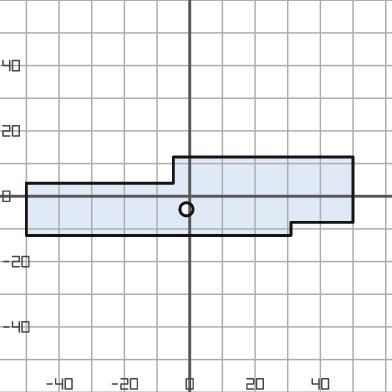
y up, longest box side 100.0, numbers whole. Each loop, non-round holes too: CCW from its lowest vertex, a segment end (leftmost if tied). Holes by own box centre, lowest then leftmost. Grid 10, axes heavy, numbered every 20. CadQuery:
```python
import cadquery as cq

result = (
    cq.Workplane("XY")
    .moveTo(-50.0, -12.0)
    .lineTo(31.0, -12.0)
    .lineTo(31.0, -8.0)
    .lineTo(50.0, -8.0)
    .lineTo(50.0, 12.0)
    .lineTo(-5.0, 12.0)
    .lineTo(-5.0, 4.0)
    .lineTo(-50.0, 4.0)
    .close()
    .moveTo(-1.0, -4.0)
    .circle(2.0)
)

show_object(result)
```